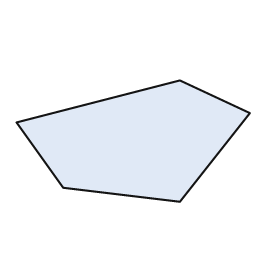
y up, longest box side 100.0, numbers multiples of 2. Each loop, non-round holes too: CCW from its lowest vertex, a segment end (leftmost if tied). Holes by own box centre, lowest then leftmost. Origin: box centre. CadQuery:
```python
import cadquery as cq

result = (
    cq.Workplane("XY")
    .moveTo(20.0, -26.0)
    .lineTo(50.0, 12.0)
    .lineTo(20.0, 26.0)
    .lineTo(-50.0, 8.0)
    .lineTo(-30.0, -20.0)
    .close()
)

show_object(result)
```